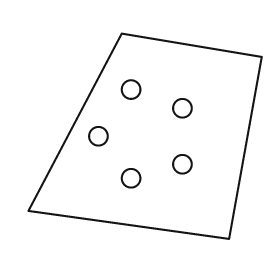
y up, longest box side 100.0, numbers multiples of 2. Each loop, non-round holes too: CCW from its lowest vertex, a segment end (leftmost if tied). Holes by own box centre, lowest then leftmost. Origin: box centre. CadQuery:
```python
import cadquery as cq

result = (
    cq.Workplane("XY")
    .moveTo(36.0, -44.0)
    .lineTo(50.0, 34.0)
    .lineTo(-10.0, 44.0)
    .lineTo(-50.0, -32.0)
    .close()
    .moveTo(-6.0, -18.0)
    .circle(4.0)
    .moveTo(16.0, -12.0)
    .circle(4.0)
    .moveTo(-20.0, 0.0)
    .circle(4.0)
    .moveTo(16.0, 12.0)
    .circle(4.0)
    .moveTo(-6.0, 20.0)
    .circle(4.0)
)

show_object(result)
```